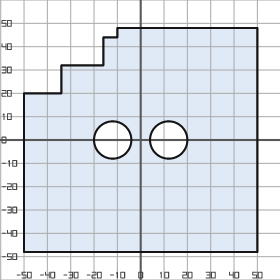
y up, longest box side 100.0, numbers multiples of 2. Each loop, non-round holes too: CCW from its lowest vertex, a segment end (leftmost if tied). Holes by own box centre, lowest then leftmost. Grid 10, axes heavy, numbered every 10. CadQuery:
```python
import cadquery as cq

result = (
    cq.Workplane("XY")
    .moveTo(-50.0, -48.0)
    .lineTo(50.0, -48.0)
    .lineTo(50.0, 48.0)
    .lineTo(-10.0, 48.0)
    .lineTo(-10.0, 44.0)
    .lineTo(-16.0, 44.0)
    .lineTo(-16.0, 32.0)
    .lineTo(-34.0, 32.0)
    .lineTo(-34.0, 20.0)
    .lineTo(-50.0, 20.0)
    .close()
    .moveTo(-12.0, 0.0)
    .circle(8.0)
    .moveTo(12.0, 0.0)
    .circle(8.0)
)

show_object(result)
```